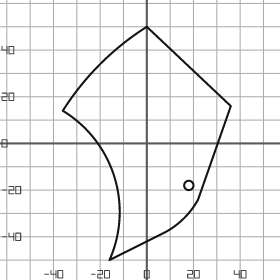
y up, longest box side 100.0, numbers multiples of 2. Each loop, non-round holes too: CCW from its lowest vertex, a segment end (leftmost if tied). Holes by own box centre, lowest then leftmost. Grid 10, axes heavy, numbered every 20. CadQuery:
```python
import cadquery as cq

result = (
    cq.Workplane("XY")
    .moveTo(-16.0, -50.0)
    .lineTo(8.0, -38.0)
    .threePointArc((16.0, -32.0), (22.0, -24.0))
    .lineTo(36.0, 16.0)
    .lineTo(0.0, 50.0)
    .threePointArc((-20.0, 34.0), (-36.0, 14.0))
    .threePointArc((-14.0, -14.0), (-16.0, -50.0))
    .close()
    .moveTo(18.0, -18.0)
    .circle(2.0)
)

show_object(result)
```